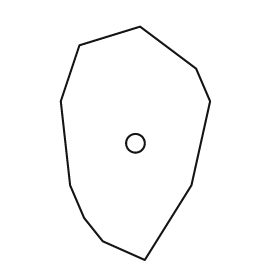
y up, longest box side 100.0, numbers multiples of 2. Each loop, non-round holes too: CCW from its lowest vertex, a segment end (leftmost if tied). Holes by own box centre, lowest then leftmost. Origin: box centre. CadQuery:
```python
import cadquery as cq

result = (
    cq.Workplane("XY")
    .moveTo(4.0, -50.0)
    .lineTo(24.0, -18.0)
    .lineTo(32.0, 18.0)
    .lineTo(26.0, 32.0)
    .lineTo(2.0, 50.0)
    .lineTo(-24.0, 42.0)
    .lineTo(-32.0, 18.0)
    .lineTo(-28.0, -18.0)
    .lineTo(-22.0, -32.0)
    .lineTo(-14.0, -42.0)
    .close()
    .moveTo(0.0, 0.0)
    .circle(4.0)
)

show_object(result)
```